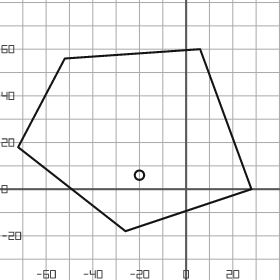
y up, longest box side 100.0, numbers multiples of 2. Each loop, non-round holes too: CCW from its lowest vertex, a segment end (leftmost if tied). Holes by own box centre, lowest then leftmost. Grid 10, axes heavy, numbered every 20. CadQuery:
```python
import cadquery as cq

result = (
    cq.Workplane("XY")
    .moveTo(-26.0, -18.0)
    .lineTo(28.0, 0.0)
    .lineTo(6.0, 60.0)
    .lineTo(-52.0, 56.0)
    .lineTo(-72.0, 18.0)
    .close()
    .moveTo(-20.0, 6.0)
    .circle(2.0)
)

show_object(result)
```